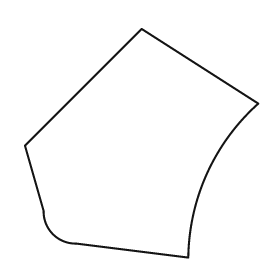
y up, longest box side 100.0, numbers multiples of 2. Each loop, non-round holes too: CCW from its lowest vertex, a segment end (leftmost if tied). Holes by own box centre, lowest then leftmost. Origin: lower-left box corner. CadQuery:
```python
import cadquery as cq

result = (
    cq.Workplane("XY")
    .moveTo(70.0, 0.0)
    .threePointArc((78.0, 36.0), (100.0, 66.0))
    .lineTo(50.0, 98.0)
    .lineTo(0.0, 48.0)
    .lineTo(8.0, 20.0)
    .threePointArc((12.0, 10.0), (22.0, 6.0))
    .close()
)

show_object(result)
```